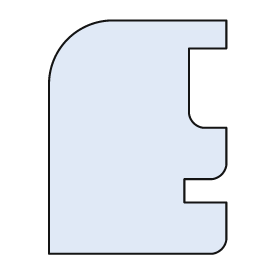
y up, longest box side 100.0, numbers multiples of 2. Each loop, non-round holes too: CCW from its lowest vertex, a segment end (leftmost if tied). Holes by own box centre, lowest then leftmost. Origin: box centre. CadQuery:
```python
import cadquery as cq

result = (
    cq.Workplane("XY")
    .moveTo(-38.0, -50.0)
    .lineTo(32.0, -50.0)
    .threePointArc((36.0, -48.0), (38.0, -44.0))
    .lineTo(38.0, -28.0)
    .lineTo(20.0, -28.0)
    .lineTo(20.0, -18.0)
    .lineTo(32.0, -18.0)
    .threePointArc((36.0, -16.0), (38.0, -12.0))
    .lineTo(38.0, 4.0)
    .lineTo(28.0, 4.0)
    .threePointArc((24.0, 6.0), (22.0, 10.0))
    .lineTo(22.0, 38.0)
    .lineTo(38.0, 38.0)
    .lineTo(38.0, 50.0)
    .lineTo(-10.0, 50.0)
    .threePointArc((-30.0, 42.0), (-38.0, 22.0))
    .close()
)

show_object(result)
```